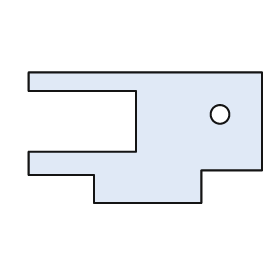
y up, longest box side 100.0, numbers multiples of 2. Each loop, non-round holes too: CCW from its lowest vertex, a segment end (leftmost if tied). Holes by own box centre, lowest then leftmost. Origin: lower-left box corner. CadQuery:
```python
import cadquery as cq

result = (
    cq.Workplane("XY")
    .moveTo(28.0, 0.0)
    .lineTo(74.0, 0.0)
    .lineTo(74.0, 14.0)
    .lineTo(100.0, 14.0)
    .lineTo(100.0, 56.0)
    .lineTo(0.0, 56.0)
    .lineTo(0.0, 48.0)
    .lineTo(46.0, 48.0)
    .lineTo(46.0, 22.0)
    .lineTo(0.0, 22.0)
    .lineTo(0.0, 12.0)
    .lineTo(28.0, 12.0)
    .close()
    .moveTo(82.0, 38.0)
    .circle(4.0)
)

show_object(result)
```